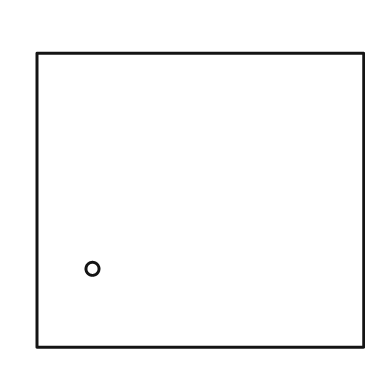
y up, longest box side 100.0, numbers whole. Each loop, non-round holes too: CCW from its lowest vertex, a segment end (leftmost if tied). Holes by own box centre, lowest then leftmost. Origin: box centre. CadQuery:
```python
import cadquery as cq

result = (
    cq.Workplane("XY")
    .moveTo(-50.0, -45.0)
    .lineTo(50.0, -45.0)
    .lineTo(50.0, 45.0)
    .lineTo(-50.0, 45.0)
    .close()
    .moveTo(-33.0, -21.0)
    .circle(2.0)
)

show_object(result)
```